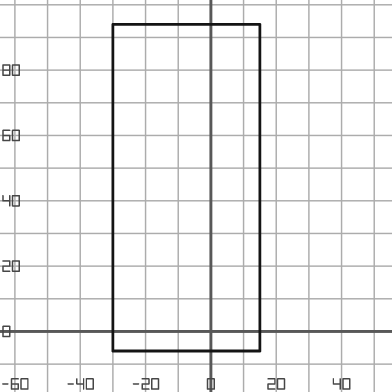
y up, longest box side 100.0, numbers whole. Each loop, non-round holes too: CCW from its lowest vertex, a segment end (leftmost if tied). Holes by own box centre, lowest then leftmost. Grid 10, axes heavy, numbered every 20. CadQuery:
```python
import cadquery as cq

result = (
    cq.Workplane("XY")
    .moveTo(-30.0, -6.0)
    .lineTo(15.0, -6.0)
    .lineTo(15.0, 94.0)
    .lineTo(-30.0, 94.0)
    .close()
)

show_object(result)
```